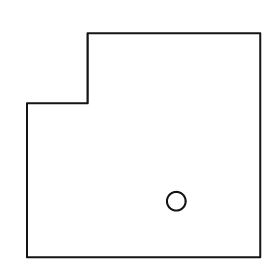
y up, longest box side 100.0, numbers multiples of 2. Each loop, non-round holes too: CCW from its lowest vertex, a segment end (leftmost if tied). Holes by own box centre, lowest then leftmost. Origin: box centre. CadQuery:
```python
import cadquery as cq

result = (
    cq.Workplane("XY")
    .moveTo(-50.0, -48.0)
    .lineTo(50.0, -48.0)
    .lineTo(50.0, 48.0)
    .lineTo(-24.0, 48.0)
    .lineTo(-24.0, 18.0)
    .lineTo(-50.0, 18.0)
    .close()
    .moveTo(14.0, -24.0)
    .circle(4.0)
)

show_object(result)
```